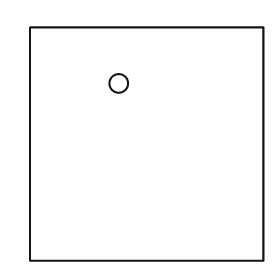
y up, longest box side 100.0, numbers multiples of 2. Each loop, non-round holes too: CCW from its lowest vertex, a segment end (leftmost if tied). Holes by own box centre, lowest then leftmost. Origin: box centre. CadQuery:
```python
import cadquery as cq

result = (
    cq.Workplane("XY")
    .moveTo(-50.0, -50.0)
    .lineTo(50.0, -50.0)
    .lineTo(50.0, 50.0)
    .lineTo(-50.0, 50.0)
    .close()
    .moveTo(-12.0, 26.0)
    .circle(4.0)
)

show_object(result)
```